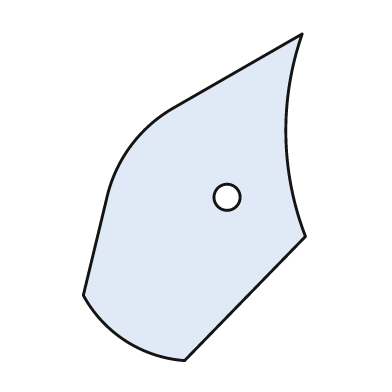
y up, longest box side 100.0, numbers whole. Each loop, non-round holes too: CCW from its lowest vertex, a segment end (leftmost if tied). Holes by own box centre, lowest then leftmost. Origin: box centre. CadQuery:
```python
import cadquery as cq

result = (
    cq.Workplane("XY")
    .moveTo(-3.0, -50.0)
    .lineTo(34.0, -12.0)
    .threePointArc((28.0, 19.0), (33.0, 50.0))
    .lineTo(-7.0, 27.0)
    .threePointArc((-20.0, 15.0), (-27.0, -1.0))
    .lineTo(-34.0, -30.0)
    .threePointArc((-21.0, -44.0), (-3.0, -50.0))
    .close()
    .moveTo(10.0, 0.0)
    .circle(4.0)
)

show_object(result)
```